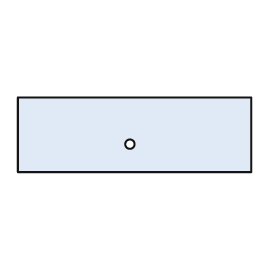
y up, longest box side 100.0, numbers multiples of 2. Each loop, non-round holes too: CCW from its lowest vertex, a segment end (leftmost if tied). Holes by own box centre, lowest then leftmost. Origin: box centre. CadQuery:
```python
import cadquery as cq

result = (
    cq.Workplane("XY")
    .moveTo(-50.0, -16.0)
    .lineTo(50.0, -16.0)
    .lineTo(50.0, 16.0)
    .lineTo(-50.0, 16.0)
    .close()
    .moveTo(-2.0, -4.0)
    .circle(2.0)
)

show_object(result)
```